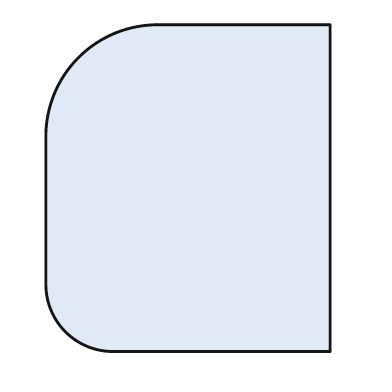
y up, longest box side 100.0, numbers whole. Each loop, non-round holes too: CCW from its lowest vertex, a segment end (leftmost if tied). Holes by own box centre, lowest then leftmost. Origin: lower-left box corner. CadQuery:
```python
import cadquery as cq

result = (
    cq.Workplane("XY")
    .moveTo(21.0, 0.0)
    .lineTo(87.0, 0.0)
    .lineTo(87.0, 100.0)
    .lineTo(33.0, 100.0)
    .threePointArc((10.0, 90.0), (0.0, 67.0))
    .lineTo(0.0, 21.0)
    .threePointArc((6.0, 6.0), (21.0, 0.0))
    .close()
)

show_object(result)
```